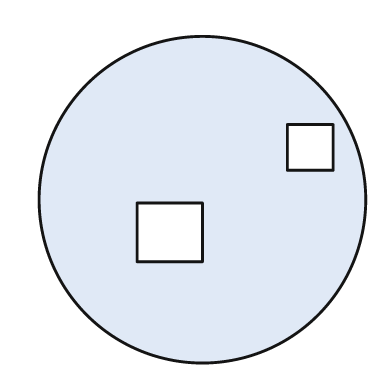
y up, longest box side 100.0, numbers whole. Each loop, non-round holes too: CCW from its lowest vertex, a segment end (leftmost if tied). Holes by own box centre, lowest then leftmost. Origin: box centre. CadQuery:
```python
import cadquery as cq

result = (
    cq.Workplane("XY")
    .moveTo(0.0, 0.0)
    .circle(50.0)
    .moveTo(-20.0, -19.0)
    .lineTo(0.0, -19.0)
    .lineTo(0.0, -1.0)
    .lineTo(-20.0, -1.0)
    .close()
    .moveTo(26.0, 9.0)
    .lineTo(40.0, 9.0)
    .lineTo(40.0, 23.0)
    .lineTo(26.0, 23.0)
    .close()
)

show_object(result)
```